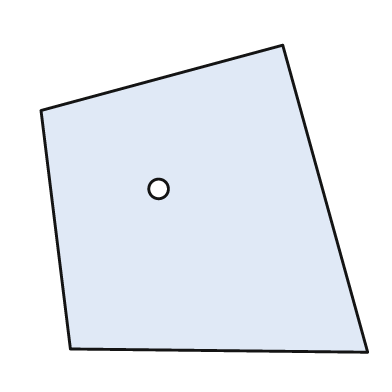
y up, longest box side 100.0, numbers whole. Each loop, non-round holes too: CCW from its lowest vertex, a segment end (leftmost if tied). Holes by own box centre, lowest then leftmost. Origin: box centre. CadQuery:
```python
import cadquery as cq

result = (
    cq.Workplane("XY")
    .moveTo(50.0, -47.0)
    .lineTo(24.0, 47.0)
    .lineTo(-50.0, 27.0)
    .lineTo(-41.0, -46.0)
    .close()
    .moveTo(-14.0, 3.0)
    .circle(3.0)
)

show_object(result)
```